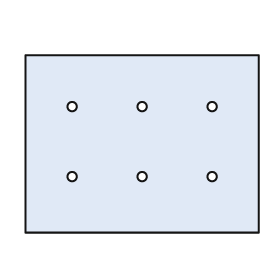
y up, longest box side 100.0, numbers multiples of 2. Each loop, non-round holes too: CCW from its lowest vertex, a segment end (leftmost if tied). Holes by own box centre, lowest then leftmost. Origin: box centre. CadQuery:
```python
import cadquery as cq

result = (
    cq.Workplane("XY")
    .moveTo(-50.0, -38.0)
    .lineTo(50.0, -38.0)
    .lineTo(50.0, 38.0)
    .lineTo(-50.0, 38.0)
    .close()
    .moveTo(-30.0, -14.0)
    .circle(2.0)
    .moveTo(0.0, -14.0)
    .circle(2.0)
    .moveTo(30.0, -14.0)
    .circle(2.0)
    .moveTo(-30.0, 16.0)
    .circle(2.0)
    .moveTo(0.0, 16.0)
    .circle(2.0)
    .moveTo(30.0, 16.0)
    .circle(2.0)
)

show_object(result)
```